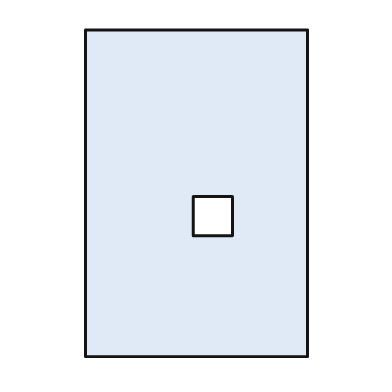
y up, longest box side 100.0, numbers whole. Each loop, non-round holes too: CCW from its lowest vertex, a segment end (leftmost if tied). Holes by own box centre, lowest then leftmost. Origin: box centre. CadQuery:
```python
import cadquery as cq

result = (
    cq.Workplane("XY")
    .moveTo(-34.0, -50.0)
    .lineTo(34.0, -50.0)
    .lineTo(34.0, 50.0)
    .lineTo(-34.0, 50.0)
    .close()
    .moveTo(-1.0, -13.0)
    .lineTo(11.0, -13.0)
    .lineTo(11.0, -1.0)
    .lineTo(-1.0, -1.0)
    .close()
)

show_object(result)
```